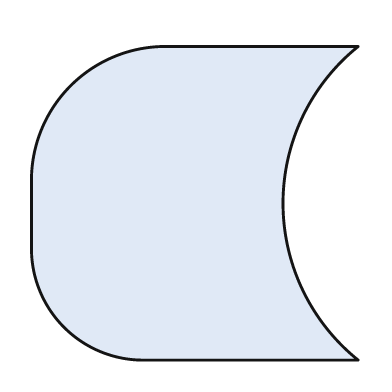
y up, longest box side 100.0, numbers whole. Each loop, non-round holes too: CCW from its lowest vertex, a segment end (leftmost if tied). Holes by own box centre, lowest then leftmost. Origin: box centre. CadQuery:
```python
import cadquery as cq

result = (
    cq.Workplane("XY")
    .moveTo(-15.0, -48.0)
    .lineTo(50.0, -48.0)
    .threePointArc((27.0, 0.0), (50.0, 48.0))
    .lineTo(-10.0, 48.0)
    .threePointArc((-38.0, 36.0), (-50.0, 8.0))
    .lineTo(-50.0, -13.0)
    .threePointArc((-40.0, -38.0), (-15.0, -48.0))
    .close()
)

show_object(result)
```